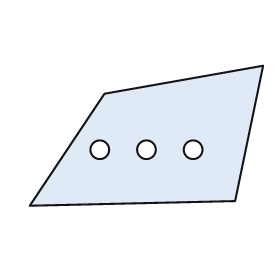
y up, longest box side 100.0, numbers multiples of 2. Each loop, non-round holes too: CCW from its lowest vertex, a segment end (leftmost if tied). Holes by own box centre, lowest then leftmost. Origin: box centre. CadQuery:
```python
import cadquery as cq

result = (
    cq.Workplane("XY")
    .moveTo(-50.0, -30.0)
    .lineTo(38.0, -28.0)
    .lineTo(50.0, 30.0)
    .lineTo(-18.0, 18.0)
    .close()
    .moveTo(-20.0, -6.0)
    .circle(4.0)
    .moveTo(0.0, -6.0)
    .circle(4.0)
    .moveTo(20.0, -6.0)
    .circle(4.0)
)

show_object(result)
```